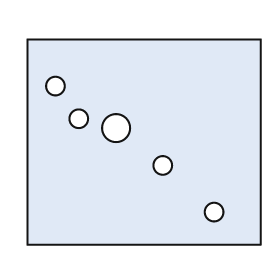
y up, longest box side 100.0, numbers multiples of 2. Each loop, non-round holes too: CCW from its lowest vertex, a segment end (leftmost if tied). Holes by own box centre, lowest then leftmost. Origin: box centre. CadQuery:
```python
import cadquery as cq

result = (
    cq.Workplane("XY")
    .moveTo(-50.0, -44.0)
    .lineTo(50.0, -44.0)
    .lineTo(50.0, 44.0)
    .lineTo(-50.0, 44.0)
    .close()
    .moveTo(30.0, -30.0)
    .circle(4.0)
    .moveTo(8.0, -10.0)
    .circle(4.0)
    .moveTo(-12.0, 6.0)
    .circle(6.0)
    .moveTo(-28.0, 10.0)
    .circle(4.0)
    .moveTo(-38.0, 24.0)
    .circle(4.0)
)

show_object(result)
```